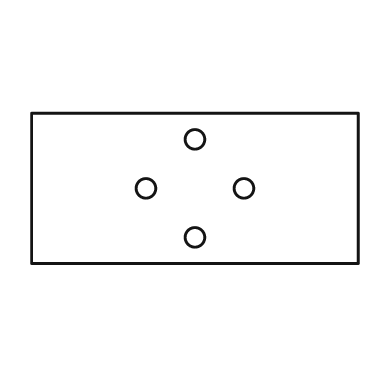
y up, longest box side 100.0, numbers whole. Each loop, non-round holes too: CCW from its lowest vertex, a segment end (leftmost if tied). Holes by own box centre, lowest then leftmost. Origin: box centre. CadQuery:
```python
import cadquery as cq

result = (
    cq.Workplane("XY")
    .moveTo(-50.0, -23.0)
    .lineTo(50.0, -23.0)
    .lineTo(50.0, 23.0)
    .lineTo(-50.0, 23.0)
    .close()
    .moveTo(0.0, -15.0)
    .circle(3.0)
    .moveTo(-15.0, 0.0)
    .circle(3.0)
    .moveTo(15.0, 0.0)
    .circle(3.0)
    .moveTo(0.0, 15.0)
    .circle(3.0)
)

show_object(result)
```